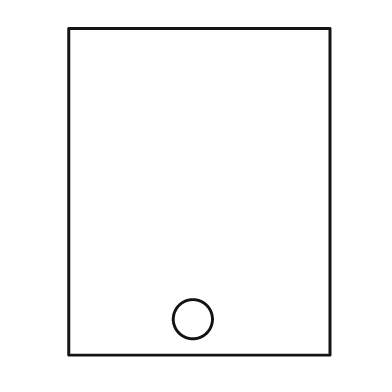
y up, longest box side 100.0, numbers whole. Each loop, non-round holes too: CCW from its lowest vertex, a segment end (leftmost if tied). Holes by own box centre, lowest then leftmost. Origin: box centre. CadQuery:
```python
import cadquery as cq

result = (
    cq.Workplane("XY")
    .moveTo(-40.0, -50.0)
    .lineTo(40.0, -50.0)
    .lineTo(40.0, 50.0)
    .lineTo(-40.0, 50.0)
    .close()
    .moveTo(-2.0, -39.0)
    .circle(6.0)
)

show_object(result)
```